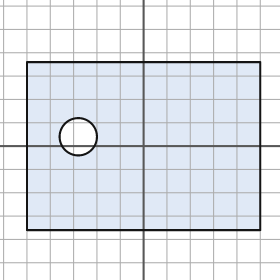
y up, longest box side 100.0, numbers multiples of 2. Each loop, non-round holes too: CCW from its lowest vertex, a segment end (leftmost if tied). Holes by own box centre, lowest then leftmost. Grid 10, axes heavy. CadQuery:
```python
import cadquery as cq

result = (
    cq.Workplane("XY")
    .moveTo(-50.0, -36.0)
    .lineTo(50.0, -36.0)
    .lineTo(50.0, 36.0)
    .lineTo(-50.0, 36.0)
    .close()
    .moveTo(-28.0, 4.0)
    .circle(8.0)
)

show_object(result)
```